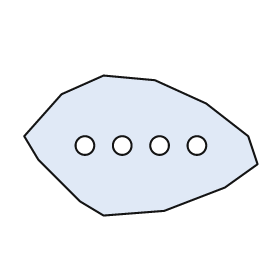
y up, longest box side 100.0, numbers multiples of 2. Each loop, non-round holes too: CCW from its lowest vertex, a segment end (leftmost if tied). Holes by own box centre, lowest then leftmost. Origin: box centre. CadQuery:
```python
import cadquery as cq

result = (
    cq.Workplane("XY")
    .moveTo(-16.0, -30.0)
    .lineTo(10.0, -28.0)
    .lineTo(36.0, -18.0)
    .lineTo(50.0, -8.0)
    .lineTo(46.0, 4.0)
    .lineTo(28.0, 18.0)
    .lineTo(6.0, 28.0)
    .lineTo(-16.0, 30.0)
    .lineTo(-34.0, 22.0)
    .lineTo(-50.0, 4.0)
    .lineTo(-44.0, -6.0)
    .lineTo(-26.0, -24.0)
    .close()
    .moveTo(-24.0, 0.0)
    .circle(4.0)
    .moveTo(-8.0, 0.0)
    .circle(4.0)
    .moveTo(8.0, 0.0)
    .circle(4.0)
    .moveTo(24.0, 0.0)
    .circle(4.0)
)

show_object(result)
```